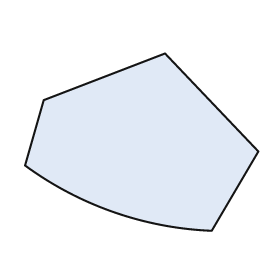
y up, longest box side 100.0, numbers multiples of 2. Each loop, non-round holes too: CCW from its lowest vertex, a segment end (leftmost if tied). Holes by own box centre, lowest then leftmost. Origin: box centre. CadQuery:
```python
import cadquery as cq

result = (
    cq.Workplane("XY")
    .moveTo(30.0, -38.0)
    .lineTo(50.0, -4.0)
    .lineTo(10.0, 38.0)
    .lineTo(-42.0, 18.0)
    .lineTo(-50.0, -10.0)
    .threePointArc((-12.0, -30.0), (30.0, -38.0))
    .close()
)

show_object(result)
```